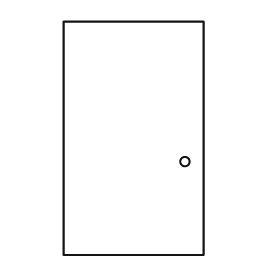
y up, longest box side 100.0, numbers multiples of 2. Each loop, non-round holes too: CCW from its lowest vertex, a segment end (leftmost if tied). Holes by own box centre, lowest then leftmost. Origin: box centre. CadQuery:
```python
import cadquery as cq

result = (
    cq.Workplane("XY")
    .moveTo(-30.0, -50.0)
    .lineTo(30.0, -50.0)
    .lineTo(30.0, 50.0)
    .lineTo(-30.0, 50.0)
    .close()
    .moveTo(22.0, -10.0)
    .circle(2.0)
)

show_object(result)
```